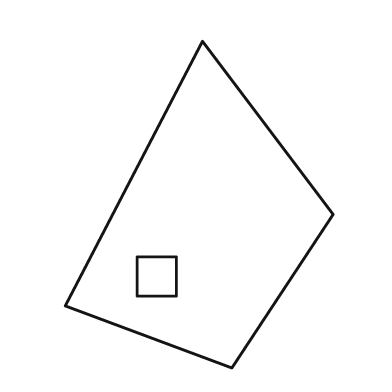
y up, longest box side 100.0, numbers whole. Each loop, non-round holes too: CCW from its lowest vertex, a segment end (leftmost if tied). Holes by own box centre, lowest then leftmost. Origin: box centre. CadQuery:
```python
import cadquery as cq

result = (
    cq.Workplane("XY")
    .moveTo(10.0, -50.0)
    .lineTo(41.0, -3.0)
    .lineTo(1.0, 50.0)
    .lineTo(-41.0, -31.0)
    .close()
    .moveTo(-19.0, -28.0)
    .lineTo(-7.0, -28.0)
    .lineTo(-7.0, -16.0)
    .lineTo(-19.0, -16.0)
    .close()
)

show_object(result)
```